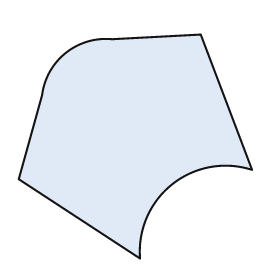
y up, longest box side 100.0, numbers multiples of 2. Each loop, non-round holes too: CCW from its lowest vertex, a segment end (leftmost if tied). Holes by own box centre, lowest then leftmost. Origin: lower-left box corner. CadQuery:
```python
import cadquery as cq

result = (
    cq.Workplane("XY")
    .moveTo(52.0, 0.0)
    .threePointArc((66.0, 32.0), (100.0, 38.0))
    .lineTo(78.0, 96.0)
    .lineTo(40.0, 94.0)
    .threePointArc((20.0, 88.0), (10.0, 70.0))
    .lineTo(0.0, 34.0)
    .close()
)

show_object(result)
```